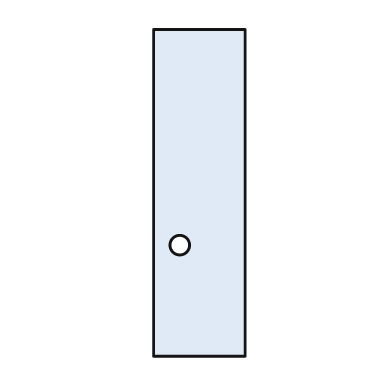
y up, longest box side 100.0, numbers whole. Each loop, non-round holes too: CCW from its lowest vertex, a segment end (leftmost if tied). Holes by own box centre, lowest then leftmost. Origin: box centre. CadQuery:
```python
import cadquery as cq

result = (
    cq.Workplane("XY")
    .moveTo(-14.0, -50.0)
    .lineTo(14.0, -50.0)
    .lineTo(14.0, 50.0)
    .lineTo(-14.0, 50.0)
    .close()
    .moveTo(-6.0, -16.0)
    .circle(3.0)
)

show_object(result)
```